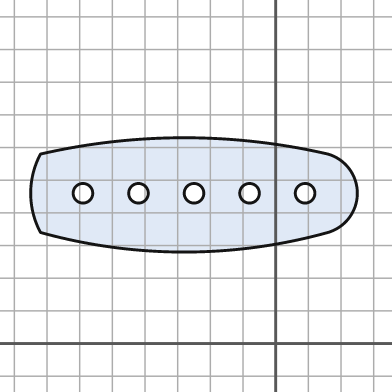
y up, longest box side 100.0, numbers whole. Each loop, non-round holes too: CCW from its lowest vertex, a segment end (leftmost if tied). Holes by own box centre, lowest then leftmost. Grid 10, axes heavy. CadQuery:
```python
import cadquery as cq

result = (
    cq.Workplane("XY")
    .moveTo(-72.0, 34.0)
    .threePointArc((-28.0, 28.0), (16.0, 34.0))
    .threePointArc((25.0, 46.0), (16.0, 58.0))
    .threePointArc((-28.0, 63.0), (-72.0, 58.0))
    .threePointArc((-75.0, 46.0), (-72.0, 34.0))
    .close()
    .moveTo(-59.0, 46.0)
    .circle(3.0)
    .moveTo(-42.0, 46.0)
    .circle(3.0)
    .moveTo(-25.0, 46.0)
    .circle(3.0)
    .moveTo(-8.0, 46.0)
    .circle(3.0)
    .moveTo(9.0, 46.0)
    .circle(3.0)
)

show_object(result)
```